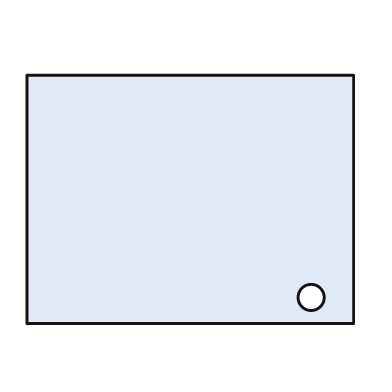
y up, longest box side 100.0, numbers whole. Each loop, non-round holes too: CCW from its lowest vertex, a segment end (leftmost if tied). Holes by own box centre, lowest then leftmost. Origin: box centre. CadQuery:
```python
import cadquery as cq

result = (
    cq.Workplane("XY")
    .moveTo(-50.0, -38.0)
    .lineTo(50.0, -38.0)
    .lineTo(50.0, 38.0)
    .lineTo(-50.0, 38.0)
    .close()
    .moveTo(37.0, -30.0)
    .circle(4.0)
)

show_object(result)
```